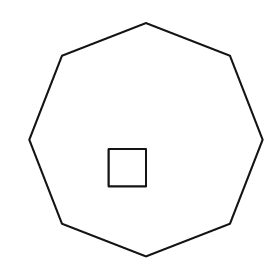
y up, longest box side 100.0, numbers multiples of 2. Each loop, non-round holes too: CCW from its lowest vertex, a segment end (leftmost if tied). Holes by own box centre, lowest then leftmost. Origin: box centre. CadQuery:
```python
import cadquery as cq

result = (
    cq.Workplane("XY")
    .moveTo(0.0, -50.0)
    .lineTo(36.0, -36.0)
    .lineTo(50.0, 0.0)
    .lineTo(36.0, 36.0)
    .lineTo(0.0, 50.0)
    .lineTo(-36.0, 36.0)
    .lineTo(-50.0, 0.0)
    .lineTo(-36.0, -36.0)
    .close()
    .moveTo(-16.0, -20.0)
    .lineTo(0.0, -20.0)
    .lineTo(0.0, -4.0)
    .lineTo(-16.0, -4.0)
    .close()
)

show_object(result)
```